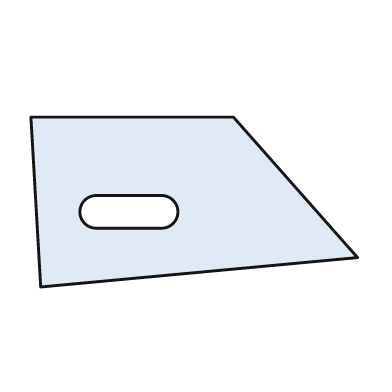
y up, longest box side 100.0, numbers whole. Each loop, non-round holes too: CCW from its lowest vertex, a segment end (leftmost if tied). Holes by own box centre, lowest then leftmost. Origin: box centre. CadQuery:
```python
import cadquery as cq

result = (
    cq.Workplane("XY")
    .moveTo(-47.0, -26.0)
    .lineTo(50.0, -17.0)
    .lineTo(12.0, 26.0)
    .lineTo(-50.0, 26.0)
    .close()
    .moveTo(-30.0, -8.0)
    .lineTo(-10.0, -8.0)
    .threePointArc((-5.0, -3.0), (-10.0, 2.0))
    .lineTo(-30.0, 2.0)
    .threePointArc((-35.0, -3.0), (-30.0, -8.0))
    .close()
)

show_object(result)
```